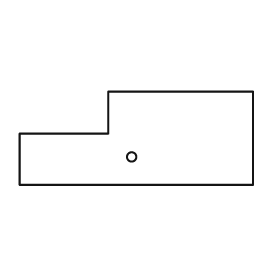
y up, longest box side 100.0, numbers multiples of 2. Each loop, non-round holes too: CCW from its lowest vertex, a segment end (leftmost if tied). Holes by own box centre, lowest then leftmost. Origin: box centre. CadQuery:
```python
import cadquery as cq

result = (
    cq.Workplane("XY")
    .moveTo(-50.0, -20.0)
    .lineTo(50.0, -20.0)
    .lineTo(50.0, 20.0)
    .lineTo(-12.0, 20.0)
    .lineTo(-12.0, 2.0)
    .lineTo(-50.0, 2.0)
    .close()
    .moveTo(-2.0, -8.0)
    .circle(2.0)
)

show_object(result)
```